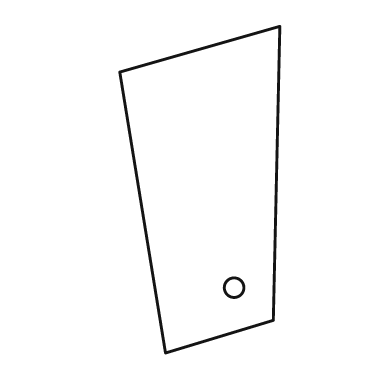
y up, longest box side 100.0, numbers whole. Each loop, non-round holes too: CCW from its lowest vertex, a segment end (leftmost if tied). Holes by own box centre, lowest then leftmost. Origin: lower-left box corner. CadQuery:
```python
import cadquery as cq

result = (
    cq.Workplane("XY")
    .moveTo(14.0, 0.0)
    .lineTo(47.0, 10.0)
    .lineTo(49.0, 100.0)
    .lineTo(0.0, 86.0)
    .close()
    .moveTo(35.0, 20.0)
    .circle(3.0)
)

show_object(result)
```